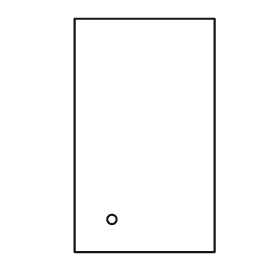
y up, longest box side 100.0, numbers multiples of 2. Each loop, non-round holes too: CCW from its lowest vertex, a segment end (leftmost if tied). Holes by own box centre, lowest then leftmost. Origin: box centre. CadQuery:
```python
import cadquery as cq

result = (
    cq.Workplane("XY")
    .moveTo(-30.0, -50.0)
    .lineTo(30.0, -50.0)
    .lineTo(30.0, 50.0)
    .lineTo(-30.0, 50.0)
    .close()
    .moveTo(-14.0, -36.0)
    .circle(2.0)
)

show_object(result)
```